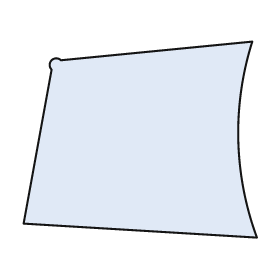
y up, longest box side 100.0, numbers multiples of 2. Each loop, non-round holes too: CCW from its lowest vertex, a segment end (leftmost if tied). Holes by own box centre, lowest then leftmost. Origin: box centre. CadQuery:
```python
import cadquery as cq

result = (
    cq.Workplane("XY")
    .moveTo(50.0, -42.0)
    .threePointArc((42.0, 0.0), (48.0, 42.0))
    .lineTo(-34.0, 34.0)
    .threePointArc((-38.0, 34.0), (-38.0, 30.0))
    .lineTo(-50.0, -36.0)
    .close()
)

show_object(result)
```